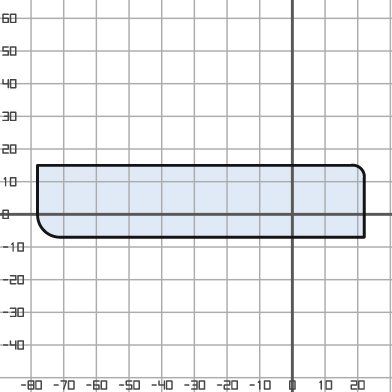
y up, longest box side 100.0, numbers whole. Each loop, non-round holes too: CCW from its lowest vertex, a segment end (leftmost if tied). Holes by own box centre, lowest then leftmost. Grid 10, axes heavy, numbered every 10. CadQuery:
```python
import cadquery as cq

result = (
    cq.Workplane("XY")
    .moveTo(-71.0, -7.0)
    .lineTo(22.0, -7.0)
    .lineTo(22.0, 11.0)
    .threePointArc((21.0, 14.0), (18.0, 15.0))
    .lineTo(-78.0, 15.0)
    .lineTo(-78.0, 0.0)
    .threePointArc((-76.0, -5.0), (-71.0, -7.0))
    .close()
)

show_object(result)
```